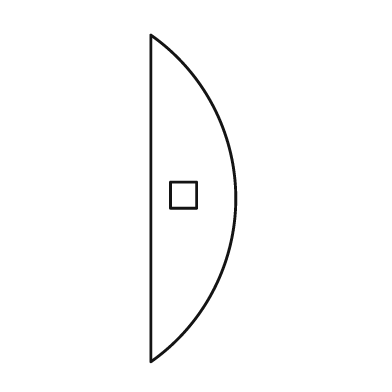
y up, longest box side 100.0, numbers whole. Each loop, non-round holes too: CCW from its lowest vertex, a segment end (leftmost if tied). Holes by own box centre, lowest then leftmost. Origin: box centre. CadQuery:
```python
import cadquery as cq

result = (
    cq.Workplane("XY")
    .moveTo(-13.0, -50.0)
    .threePointArc((13.0, 0.0), (-13.0, 50.0))
    .close()
    .moveTo(-7.0, -3.0)
    .lineTo(1.0, -3.0)
    .lineTo(1.0, 5.0)
    .lineTo(-7.0, 5.0)
    .close()
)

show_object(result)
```